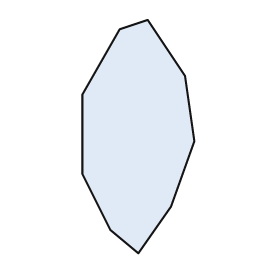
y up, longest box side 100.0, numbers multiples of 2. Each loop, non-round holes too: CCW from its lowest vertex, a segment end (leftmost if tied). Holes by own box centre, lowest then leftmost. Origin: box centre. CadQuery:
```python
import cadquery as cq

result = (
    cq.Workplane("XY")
    .moveTo(0.0, -50.0)
    .lineTo(14.0, -30.0)
    .lineTo(24.0, -2.0)
    .lineTo(20.0, 26.0)
    .lineTo(4.0, 50.0)
    .lineTo(-8.0, 46.0)
    .lineTo(-24.0, 18.0)
    .lineTo(-24.0, -16.0)
    .lineTo(-12.0, -40.0)
    .close()
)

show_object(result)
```